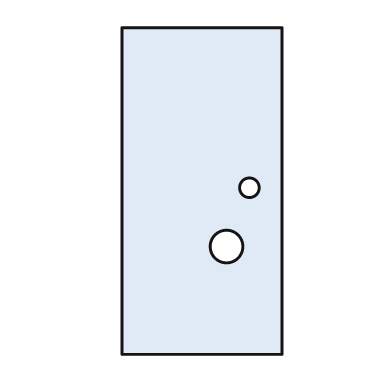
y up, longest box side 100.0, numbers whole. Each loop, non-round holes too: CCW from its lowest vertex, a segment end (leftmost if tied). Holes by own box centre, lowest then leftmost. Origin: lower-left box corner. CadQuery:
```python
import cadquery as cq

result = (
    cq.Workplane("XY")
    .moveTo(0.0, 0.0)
    .lineTo(49.0, 0.0)
    .lineTo(49.0, 100.0)
    .lineTo(0.0, 100.0)
    .close()
    .moveTo(32.0, 33.0)
    .circle(5.0)
    .moveTo(39.0, 51.0)
    .circle(3.0)
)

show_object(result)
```